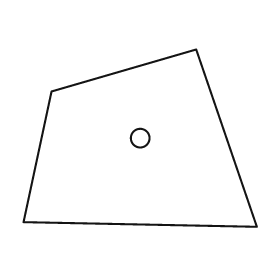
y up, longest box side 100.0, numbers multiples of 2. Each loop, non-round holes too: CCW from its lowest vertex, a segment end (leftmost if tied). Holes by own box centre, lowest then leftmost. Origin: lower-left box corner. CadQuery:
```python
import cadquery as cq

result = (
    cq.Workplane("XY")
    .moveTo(100.0, 0.0)
    .lineTo(74.0, 76.0)
    .lineTo(12.0, 58.0)
    .lineTo(0.0, 2.0)
    .close()
    .moveTo(50.0, 38.0)
    .circle(4.0)
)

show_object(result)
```